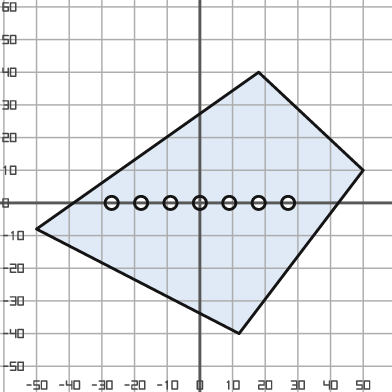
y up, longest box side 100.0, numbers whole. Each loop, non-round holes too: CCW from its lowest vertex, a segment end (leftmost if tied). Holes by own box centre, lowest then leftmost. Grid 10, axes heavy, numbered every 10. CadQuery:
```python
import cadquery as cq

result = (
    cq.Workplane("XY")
    .moveTo(12.0, -40.0)
    .lineTo(50.0, 10.0)
    .lineTo(18.0, 40.0)
    .lineTo(-50.0, -8.0)
    .close()
    .moveTo(-27.0, 0.0)
    .circle(2.0)
    .moveTo(-18.0, 0.0)
    .circle(2.0)
    .moveTo(-9.0, 0.0)
    .circle(2.0)
    .moveTo(0.0, 0.0)
    .circle(2.0)
    .moveTo(9.0, 0.0)
    .circle(2.0)
    .moveTo(18.0, 0.0)
    .circle(2.0)
    .moveTo(27.0, 0.0)
    .circle(2.0)
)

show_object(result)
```